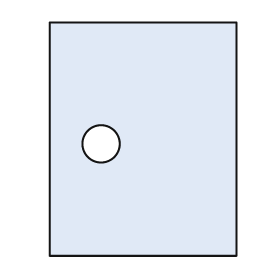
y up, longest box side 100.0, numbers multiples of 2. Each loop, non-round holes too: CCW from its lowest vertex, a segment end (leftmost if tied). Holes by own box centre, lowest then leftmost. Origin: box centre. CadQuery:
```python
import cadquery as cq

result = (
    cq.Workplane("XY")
    .moveTo(-40.0, -50.0)
    .lineTo(40.0, -50.0)
    .lineTo(40.0, 50.0)
    .lineTo(-40.0, 50.0)
    .close()
    .moveTo(-18.0, -2.0)
    .circle(8.0)
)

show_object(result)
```